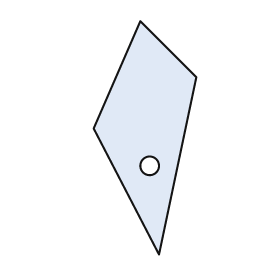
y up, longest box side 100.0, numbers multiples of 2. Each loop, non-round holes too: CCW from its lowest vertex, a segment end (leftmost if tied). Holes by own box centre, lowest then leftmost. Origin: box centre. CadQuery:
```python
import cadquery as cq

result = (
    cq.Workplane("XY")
    .moveTo(6.0, -50.0)
    .lineTo(22.0, 26.0)
    .lineTo(-2.0, 50.0)
    .lineTo(-22.0, 4.0)
    .close()
    .moveTo(2.0, -12.0)
    .circle(4.0)
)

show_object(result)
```